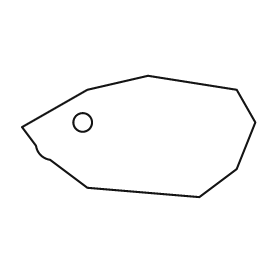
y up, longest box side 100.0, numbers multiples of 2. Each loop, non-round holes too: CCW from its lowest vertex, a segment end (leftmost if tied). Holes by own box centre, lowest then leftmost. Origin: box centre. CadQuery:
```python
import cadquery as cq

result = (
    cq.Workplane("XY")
    .moveTo(26.0, -26.0)
    .lineTo(42.0, -14.0)
    .lineTo(50.0, 6.0)
    .lineTo(42.0, 20.0)
    .lineTo(4.0, 26.0)
    .lineTo(-22.0, 20.0)
    .lineTo(-50.0, 4.0)
    .lineTo(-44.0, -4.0)
    .threePointArc((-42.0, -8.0), (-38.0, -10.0))
    .lineTo(-22.0, -22.0)
    .close()
    .moveTo(-24.0, 6.0)
    .circle(4.0)
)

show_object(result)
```